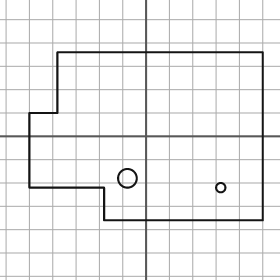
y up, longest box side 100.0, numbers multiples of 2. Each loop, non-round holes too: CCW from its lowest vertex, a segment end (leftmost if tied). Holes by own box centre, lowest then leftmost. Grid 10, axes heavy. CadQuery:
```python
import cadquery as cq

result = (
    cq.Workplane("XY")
    .moveTo(-18.0, -36.0)
    .lineTo(50.0, -36.0)
    .lineTo(50.0, 36.0)
    .lineTo(-38.0, 36.0)
    .lineTo(-38.0, 10.0)
    .lineTo(-50.0, 10.0)
    .lineTo(-50.0, -22.0)
    .lineTo(-18.0, -22.0)
    .close()
    .moveTo(32.0, -22.0)
    .circle(2.0)
    .moveTo(-8.0, -18.0)
    .circle(4.0)
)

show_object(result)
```